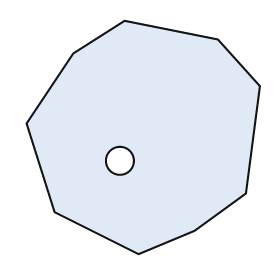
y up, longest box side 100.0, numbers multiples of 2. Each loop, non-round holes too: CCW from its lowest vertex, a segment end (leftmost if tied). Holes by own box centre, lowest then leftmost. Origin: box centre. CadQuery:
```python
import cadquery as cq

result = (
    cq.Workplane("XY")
    .moveTo(-2.0, -50.0)
    .lineTo(22.0, -40.0)
    .lineTo(44.0, -24.0)
    .lineTo(50.0, 22.0)
    .lineTo(32.0, 42.0)
    .lineTo(-8.0, 50.0)
    .lineTo(-30.0, 36.0)
    .lineTo(-50.0, 6.0)
    .lineTo(-38.0, -32.0)
    .close()
    .moveTo(-10.0, -10.0)
    .circle(6.0)
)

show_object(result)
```